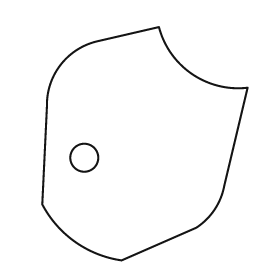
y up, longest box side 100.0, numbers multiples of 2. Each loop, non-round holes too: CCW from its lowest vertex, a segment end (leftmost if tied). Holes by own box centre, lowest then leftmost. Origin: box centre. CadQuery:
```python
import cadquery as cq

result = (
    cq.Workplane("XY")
    .moveTo(-10.0, -50.0)
    .lineTo(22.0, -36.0)
    .threePointArc((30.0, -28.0), (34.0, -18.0))
    .lineTo(44.0, 24.0)
    .threePointArc((20.0, 30.0), (6.0, 50.0))
    .lineTo(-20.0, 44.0)
    .threePointArc((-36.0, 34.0), (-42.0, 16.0))
    .lineTo(-44.0, -26.0)
    .threePointArc((-30.0, -42.0), (-10.0, -50.0))
    .close()
    .moveTo(-26.0, -6.0)
    .circle(6.0)
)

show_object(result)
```